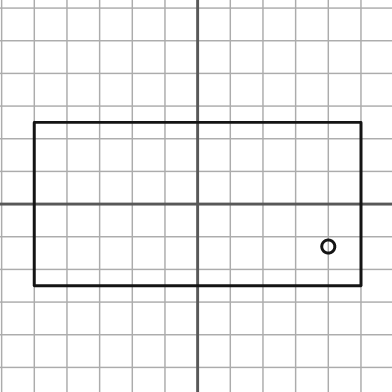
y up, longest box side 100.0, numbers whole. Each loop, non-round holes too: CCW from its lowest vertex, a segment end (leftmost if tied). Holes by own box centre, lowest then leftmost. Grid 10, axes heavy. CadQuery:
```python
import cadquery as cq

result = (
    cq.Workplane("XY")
    .moveTo(-50.0, -25.0)
    .lineTo(50.0, -25.0)
    .lineTo(50.0, 25.0)
    .lineTo(-50.0, 25.0)
    .close()
    .moveTo(40.0, -13.0)
    .circle(2.0)
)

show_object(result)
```